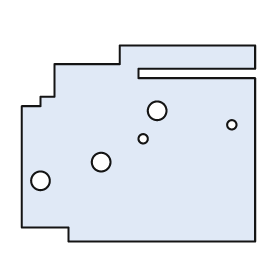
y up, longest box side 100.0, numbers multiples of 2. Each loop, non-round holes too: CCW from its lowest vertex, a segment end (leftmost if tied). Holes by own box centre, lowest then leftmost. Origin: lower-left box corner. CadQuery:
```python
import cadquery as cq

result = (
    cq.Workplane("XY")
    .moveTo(20.0, 0.0)
    .lineTo(100.0, 0.0)
    .lineTo(100.0, 70.0)
    .lineTo(50.0, 70.0)
    .lineTo(50.0, 74.0)
    .lineTo(100.0, 74.0)
    .lineTo(100.0, 84.0)
    .lineTo(42.0, 84.0)
    .lineTo(42.0, 76.0)
    .lineTo(14.0, 76.0)
    .lineTo(14.0, 62.0)
    .lineTo(8.0, 62.0)
    .lineTo(8.0, 58.0)
    .lineTo(0.0, 58.0)
    .lineTo(0.0, 6.0)
    .lineTo(20.0, 6.0)
    .close()
    .moveTo(8.0, 26.0)
    .circle(4.0)
    .moveTo(34.0, 34.0)
    .circle(4.0)
    .moveTo(52.0, 44.0)
    .circle(2.0)
    .moveTo(90.0, 50.0)
    .circle(2.0)
    .moveTo(58.0, 56.0)
    .circle(4.0)
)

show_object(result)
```